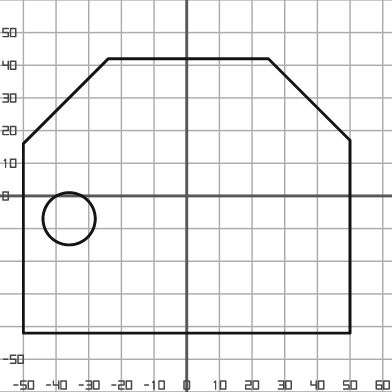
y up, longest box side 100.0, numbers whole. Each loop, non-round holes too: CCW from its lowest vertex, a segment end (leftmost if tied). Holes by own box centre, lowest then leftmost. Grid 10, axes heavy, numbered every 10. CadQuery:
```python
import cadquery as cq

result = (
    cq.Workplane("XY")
    .moveTo(-50.0, -42.0)
    .lineTo(50.0, -42.0)
    .lineTo(50.0, 17.0)
    .lineTo(25.0, 42.0)
    .lineTo(-24.0, 42.0)
    .lineTo(-50.0, 16.0)
    .close()
    .moveTo(-36.0, -7.0)
    .circle(8.0)
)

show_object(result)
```